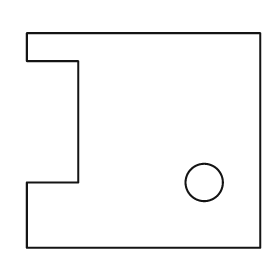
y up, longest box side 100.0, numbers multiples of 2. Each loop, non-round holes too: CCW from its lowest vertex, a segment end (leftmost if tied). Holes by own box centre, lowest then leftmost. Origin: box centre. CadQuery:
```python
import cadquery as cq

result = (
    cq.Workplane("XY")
    .moveTo(-50.0, -46.0)
    .lineTo(50.0, -46.0)
    .lineTo(50.0, 46.0)
    .lineTo(-50.0, 46.0)
    .lineTo(-50.0, 34.0)
    .lineTo(-28.0, 34.0)
    .lineTo(-28.0, -18.0)
    .lineTo(-50.0, -18.0)
    .close()
    .moveTo(26.0, -18.0)
    .circle(8.0)
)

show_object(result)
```